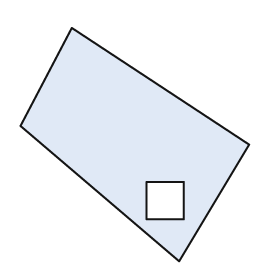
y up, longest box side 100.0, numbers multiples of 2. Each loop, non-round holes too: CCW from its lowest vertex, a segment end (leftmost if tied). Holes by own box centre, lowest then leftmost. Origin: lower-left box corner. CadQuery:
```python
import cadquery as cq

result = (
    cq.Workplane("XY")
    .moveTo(68.0, 0.0)
    .lineTo(98.0, 50.0)
    .lineTo(22.0, 100.0)
    .lineTo(0.0, 58.0)
    .close()
    .moveTo(54.0, 18.0)
    .lineTo(70.0, 18.0)
    .lineTo(70.0, 34.0)
    .lineTo(54.0, 34.0)
    .close()
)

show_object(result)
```